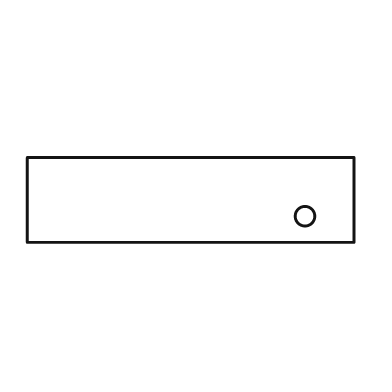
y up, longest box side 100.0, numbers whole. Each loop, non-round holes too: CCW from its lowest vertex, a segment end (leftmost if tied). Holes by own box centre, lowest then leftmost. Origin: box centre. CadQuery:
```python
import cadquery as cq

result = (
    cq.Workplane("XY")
    .moveTo(-50.0, -13.0)
    .lineTo(50.0, -13.0)
    .lineTo(50.0, 13.0)
    .lineTo(-50.0, 13.0)
    .close()
    .moveTo(35.0, -5.0)
    .circle(3.0)
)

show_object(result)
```